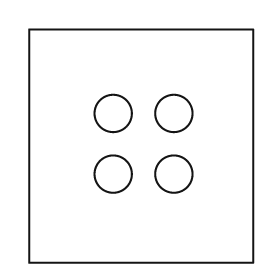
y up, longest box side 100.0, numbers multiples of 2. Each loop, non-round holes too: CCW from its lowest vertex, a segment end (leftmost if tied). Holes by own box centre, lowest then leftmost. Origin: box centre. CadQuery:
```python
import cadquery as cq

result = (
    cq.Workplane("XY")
    .moveTo(-48.0, -50.0)
    .lineTo(48.0, -50.0)
    .lineTo(48.0, 50.0)
    .lineTo(-48.0, 50.0)
    .close()
    .moveTo(-12.0, -12.0)
    .circle(8.0)
    .moveTo(14.0, -12.0)
    .circle(8.0)
    .moveTo(-12.0, 14.0)
    .circle(8.0)
    .moveTo(14.0, 14.0)
    .circle(8.0)
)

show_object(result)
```